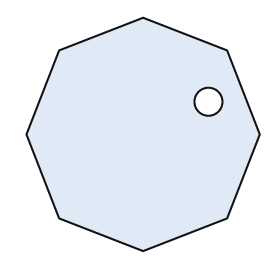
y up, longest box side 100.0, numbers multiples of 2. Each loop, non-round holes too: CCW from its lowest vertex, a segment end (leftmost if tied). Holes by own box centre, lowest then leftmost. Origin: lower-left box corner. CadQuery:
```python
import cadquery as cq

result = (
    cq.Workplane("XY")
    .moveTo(50.0, 0.0)
    .lineTo(86.0, 14.0)
    .lineTo(100.0, 50.0)
    .lineTo(86.0, 86.0)
    .lineTo(50.0, 100.0)
    .lineTo(14.0, 86.0)
    .lineTo(0.0, 50.0)
    .lineTo(14.0, 14.0)
    .close()
    .moveTo(78.0, 64.0)
    .circle(6.0)
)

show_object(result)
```